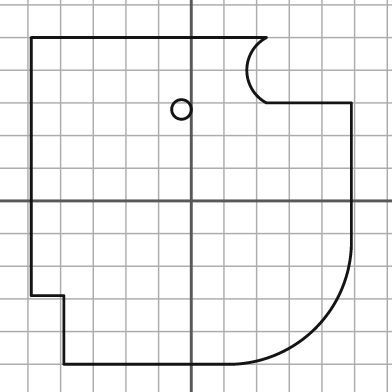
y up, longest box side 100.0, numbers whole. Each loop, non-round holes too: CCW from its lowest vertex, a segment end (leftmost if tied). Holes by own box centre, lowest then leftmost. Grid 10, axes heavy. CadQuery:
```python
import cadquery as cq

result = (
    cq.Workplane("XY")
    .moveTo(-39.0, -50.0)
    .lineTo(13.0, -50.0)
    .threePointArc((38.0, -39.0), (49.0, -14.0))
    .lineTo(49.0, 30.0)
    .lineTo(23.0, 30.0)
    .threePointArc((17.0, 40.0), (23.0, 50.0))
    .lineTo(-49.0, 50.0)
    .lineTo(-49.0, -29.0)
    .lineTo(-39.0, -29.0)
    .close()
    .moveTo(-3.0, 28.0)
    .circle(3.0)
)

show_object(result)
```